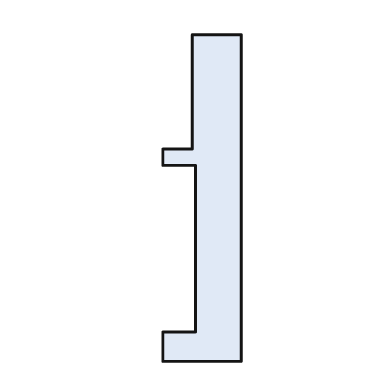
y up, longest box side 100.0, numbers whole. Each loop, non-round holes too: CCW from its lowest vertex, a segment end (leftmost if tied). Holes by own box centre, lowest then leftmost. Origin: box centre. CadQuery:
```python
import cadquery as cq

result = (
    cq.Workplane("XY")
    .moveTo(-12.0, -50.0)
    .lineTo(12.0, -50.0)
    .lineTo(12.0, 50.0)
    .lineTo(-3.0, 50.0)
    .lineTo(-3.0, 15.0)
    .lineTo(-12.0, 15.0)
    .lineTo(-12.0, 10.0)
    .lineTo(-2.0, 10.0)
    .lineTo(-2.0, -41.0)
    .lineTo(-12.0, -41.0)
    .close()
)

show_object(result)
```